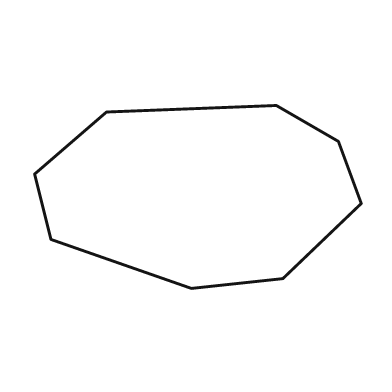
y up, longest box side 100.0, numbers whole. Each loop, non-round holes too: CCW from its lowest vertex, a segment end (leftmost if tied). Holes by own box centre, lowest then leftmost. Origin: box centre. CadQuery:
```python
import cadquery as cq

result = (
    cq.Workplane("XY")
    .moveTo(-2.0, -28.0)
    .lineTo(26.0, -25.0)
    .lineTo(50.0, -2.0)
    .lineTo(43.0, 17.0)
    .lineTo(24.0, 28.0)
    .lineTo(-28.0, 26.0)
    .lineTo(-50.0, 7.0)
    .lineTo(-45.0, -13.0)
    .close()
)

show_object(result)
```